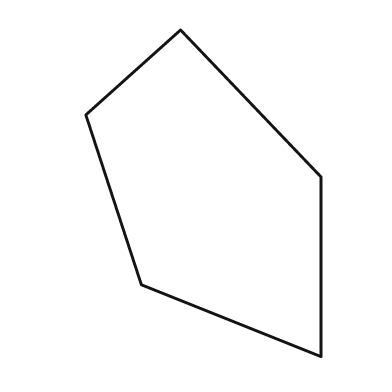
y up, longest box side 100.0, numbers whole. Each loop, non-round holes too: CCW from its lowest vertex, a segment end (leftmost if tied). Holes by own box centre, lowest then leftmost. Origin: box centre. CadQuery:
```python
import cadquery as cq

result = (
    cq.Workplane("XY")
    .moveTo(36.0, -50.0)
    .lineTo(36.0, 5.0)
    .lineTo(-7.0, 50.0)
    .lineTo(-36.0, 24.0)
    .lineTo(-19.0, -28.0)
    .close()
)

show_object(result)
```